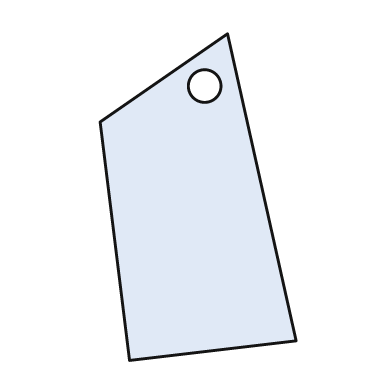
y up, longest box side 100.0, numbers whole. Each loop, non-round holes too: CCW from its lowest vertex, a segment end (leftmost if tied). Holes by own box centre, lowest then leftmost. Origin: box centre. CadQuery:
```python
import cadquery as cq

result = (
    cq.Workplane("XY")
    .moveTo(-21.0, -50.0)
    .lineTo(30.0, -44.0)
    .lineTo(9.0, 50.0)
    .lineTo(-30.0, 23.0)
    .close()
    .moveTo(2.0, 34.0)
    .circle(5.0)
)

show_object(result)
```